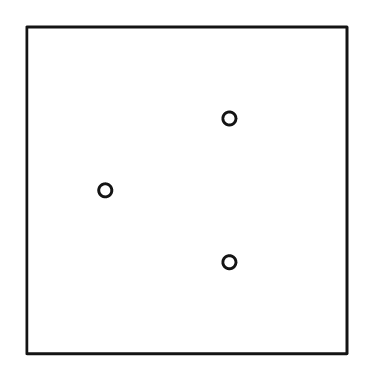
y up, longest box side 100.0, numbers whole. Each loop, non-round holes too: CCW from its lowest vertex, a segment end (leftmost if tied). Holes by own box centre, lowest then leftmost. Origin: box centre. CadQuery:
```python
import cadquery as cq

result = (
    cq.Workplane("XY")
    .moveTo(-49.0, -50.0)
    .lineTo(49.0, -50.0)
    .lineTo(49.0, 50.0)
    .lineTo(-49.0, 50.0)
    .close()
    .moveTo(13.0, -22.0)
    .circle(2.0)
    .moveTo(-25.0, 0.0)
    .circle(2.0)
    .moveTo(13.0, 22.0)
    .circle(2.0)
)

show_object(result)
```